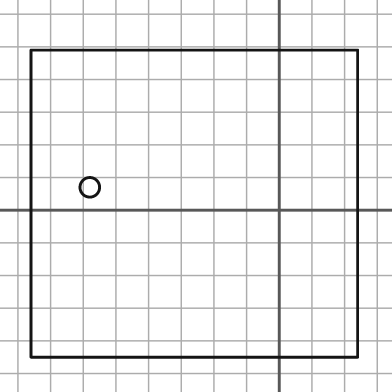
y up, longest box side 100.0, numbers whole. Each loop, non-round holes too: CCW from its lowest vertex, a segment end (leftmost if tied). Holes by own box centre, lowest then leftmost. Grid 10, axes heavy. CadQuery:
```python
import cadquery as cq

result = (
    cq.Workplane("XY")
    .moveTo(-76.0, -45.0)
    .lineTo(24.0, -45.0)
    .lineTo(24.0, 49.0)
    .lineTo(-76.0, 49.0)
    .close()
    .moveTo(-58.0, 7.0)
    .circle(3.0)
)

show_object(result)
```